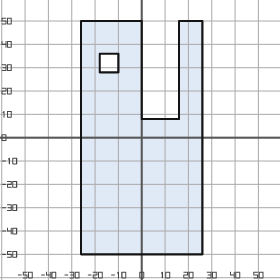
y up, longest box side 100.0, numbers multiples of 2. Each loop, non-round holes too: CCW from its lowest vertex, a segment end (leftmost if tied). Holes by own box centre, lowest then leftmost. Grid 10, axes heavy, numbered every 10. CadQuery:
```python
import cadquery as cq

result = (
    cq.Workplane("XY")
    .moveTo(-26.0, -50.0)
    .lineTo(26.0, -50.0)
    .lineTo(26.0, 50.0)
    .lineTo(16.0, 50.0)
    .lineTo(16.0, 8.0)
    .lineTo(0.0, 8.0)
    .lineTo(0.0, 50.0)
    .lineTo(-26.0, 50.0)
    .close()
    .moveTo(-18.0, 28.0)
    .lineTo(-10.0, 28.0)
    .lineTo(-10.0, 36.0)
    .lineTo(-18.0, 36.0)
    .close()
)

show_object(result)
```